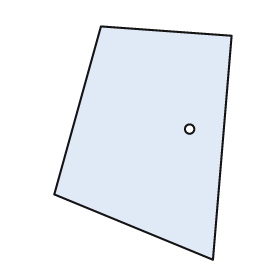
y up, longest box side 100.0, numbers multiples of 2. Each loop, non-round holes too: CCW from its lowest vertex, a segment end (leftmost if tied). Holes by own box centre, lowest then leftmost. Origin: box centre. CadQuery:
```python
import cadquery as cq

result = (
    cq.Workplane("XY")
    .moveTo(30.0, -50.0)
    .lineTo(38.0, 46.0)
    .lineTo(-18.0, 50.0)
    .lineTo(-38.0, -22.0)
    .close()
    .moveTo(20.0, 6.0)
    .circle(2.0)
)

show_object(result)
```